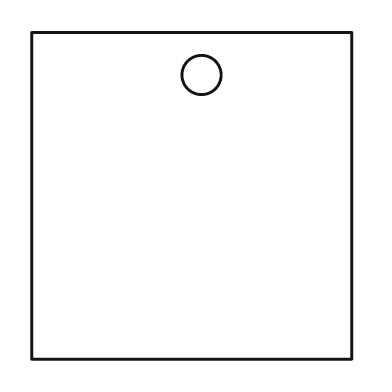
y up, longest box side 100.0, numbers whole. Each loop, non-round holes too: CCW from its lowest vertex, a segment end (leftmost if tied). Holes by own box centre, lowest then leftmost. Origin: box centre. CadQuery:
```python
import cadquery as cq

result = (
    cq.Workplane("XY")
    .moveTo(-49.0, -50.0)
    .lineTo(49.0, -50.0)
    .lineTo(49.0, 50.0)
    .lineTo(-49.0, 50.0)
    .close()
    .moveTo(3.0, 37.0)
    .circle(6.0)
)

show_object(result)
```